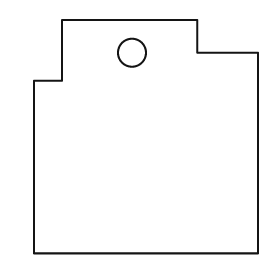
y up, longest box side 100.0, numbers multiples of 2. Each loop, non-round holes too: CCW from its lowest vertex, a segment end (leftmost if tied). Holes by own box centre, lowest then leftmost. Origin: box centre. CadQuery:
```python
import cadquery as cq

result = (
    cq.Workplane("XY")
    .moveTo(-48.0, -50.0)
    .lineTo(48.0, -50.0)
    .lineTo(48.0, 36.0)
    .lineTo(22.0, 36.0)
    .lineTo(22.0, 50.0)
    .lineTo(-36.0, 50.0)
    .lineTo(-36.0, 24.0)
    .lineTo(-48.0, 24.0)
    .close()
    .moveTo(-6.0, 36.0)
    .circle(6.0)
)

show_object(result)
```